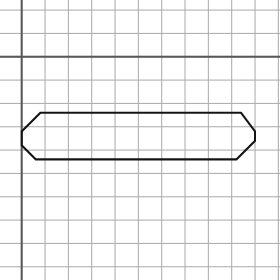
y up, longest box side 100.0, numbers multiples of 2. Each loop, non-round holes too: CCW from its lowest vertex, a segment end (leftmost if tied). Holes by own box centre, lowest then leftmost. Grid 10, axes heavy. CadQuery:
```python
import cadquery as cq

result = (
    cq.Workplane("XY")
    .moveTo(6.0, -44.0)
    .lineTo(92.0, -44.0)
    .lineTo(100.0, -36.0)
    .lineTo(100.0, -32.0)
    .lineTo(94.0, -24.0)
    .lineTo(8.0, -24.0)
    .lineTo(0.0, -32.0)
    .lineTo(0.0, -38.0)
    .close()
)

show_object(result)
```